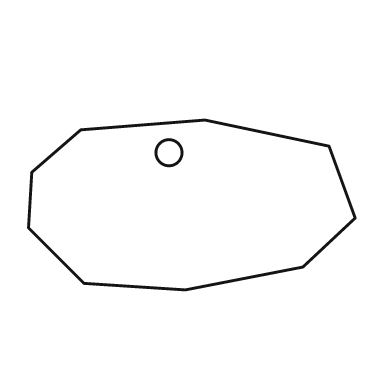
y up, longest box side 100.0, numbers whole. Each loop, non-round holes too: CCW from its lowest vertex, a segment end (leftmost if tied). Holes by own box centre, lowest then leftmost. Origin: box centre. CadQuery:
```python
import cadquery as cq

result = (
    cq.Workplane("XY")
    .moveTo(-2.0, -26.0)
    .lineTo(34.0, -19.0)
    .lineTo(50.0, -4.0)
    .lineTo(42.0, 18.0)
    .lineTo(4.0, 26.0)
    .lineTo(-34.0, 23.0)
    .lineTo(-49.0, 10.0)
    .lineTo(-50.0, -7.0)
    .lineTo(-33.0, -24.0)
    .close()
    .moveTo(-7.0, 16.0)
    .circle(4.0)
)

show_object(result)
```